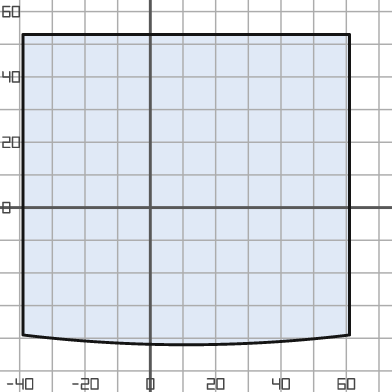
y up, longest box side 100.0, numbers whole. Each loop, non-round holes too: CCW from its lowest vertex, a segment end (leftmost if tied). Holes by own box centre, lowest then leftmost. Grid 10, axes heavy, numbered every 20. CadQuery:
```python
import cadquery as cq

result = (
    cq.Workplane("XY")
    .moveTo(-39.0, -39.0)
    .threePointArc((11.0, -42.0), (61.0, -39.0))
    .lineTo(61.0, 53.0)
    .lineTo(-39.0, 53.0)
    .close()
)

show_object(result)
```